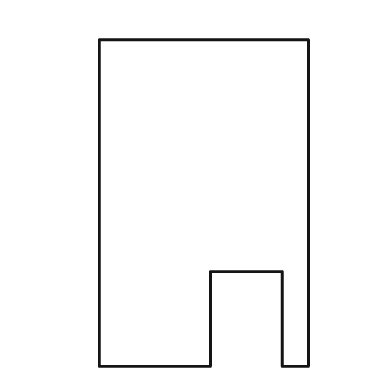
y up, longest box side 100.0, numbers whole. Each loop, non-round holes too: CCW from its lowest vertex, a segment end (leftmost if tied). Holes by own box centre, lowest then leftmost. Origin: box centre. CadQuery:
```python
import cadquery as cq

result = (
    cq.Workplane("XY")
    .moveTo(-32.0, -50.0)
    .lineTo(2.0, -50.0)
    .lineTo(2.0, -21.0)
    .lineTo(24.0, -21.0)
    .lineTo(24.0, -50.0)
    .lineTo(32.0, -50.0)
    .lineTo(32.0, 50.0)
    .lineTo(-32.0, 50.0)
    .close()
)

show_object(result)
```